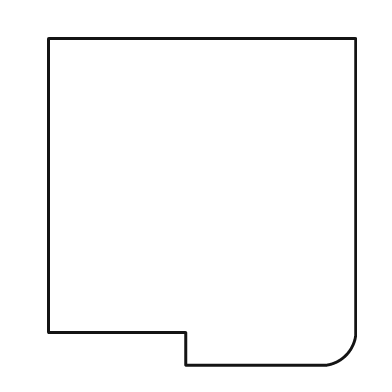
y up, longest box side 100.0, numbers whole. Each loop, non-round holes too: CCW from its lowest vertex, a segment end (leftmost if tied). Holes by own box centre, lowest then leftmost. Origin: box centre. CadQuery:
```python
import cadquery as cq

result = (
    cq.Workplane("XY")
    .moveTo(-5.0, -50.0)
    .lineTo(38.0, -50.0)
    .threePointArc((44.0, -47.0), (47.0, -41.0))
    .lineTo(47.0, 50.0)
    .lineTo(-47.0, 50.0)
    .lineTo(-47.0, -40.0)
    .lineTo(-5.0, -40.0)
    .close()
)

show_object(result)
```